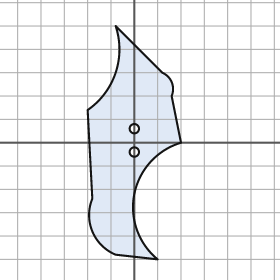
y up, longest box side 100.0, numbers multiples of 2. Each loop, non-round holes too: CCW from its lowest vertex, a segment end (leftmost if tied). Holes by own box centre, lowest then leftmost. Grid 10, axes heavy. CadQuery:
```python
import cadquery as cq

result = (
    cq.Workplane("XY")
    .moveTo(10.0, -50.0)
    .threePointArc((0.0, -22.0), (20.0, 0.0))
    .lineTo(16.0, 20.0)
    .threePointArc((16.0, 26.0), (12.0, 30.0))
    .lineTo(-8.0, 50.0)
    .threePointArc((-8.0, 30.0), (-20.0, 14.0))
    .lineTo(-18.0, -24.0)
    .threePointArc((-18.0, -38.0), (-8.0, -48.0))
    .close()
    .moveTo(0.0, -4.0)
    .circle(2.0)
    .moveTo(0.0, 6.0)
    .circle(2.0)
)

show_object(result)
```